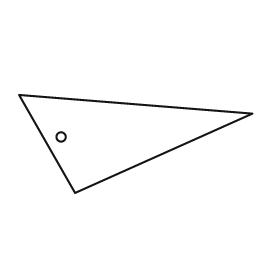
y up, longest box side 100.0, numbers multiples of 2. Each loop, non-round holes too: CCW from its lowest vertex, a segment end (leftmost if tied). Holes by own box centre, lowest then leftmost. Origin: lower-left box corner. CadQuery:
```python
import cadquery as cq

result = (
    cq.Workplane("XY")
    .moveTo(24.0, 0.0)
    .lineTo(100.0, 34.0)
    .lineTo(0.0, 42.0)
    .close()
    .moveTo(18.0, 24.0)
    .circle(2.0)
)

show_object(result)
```